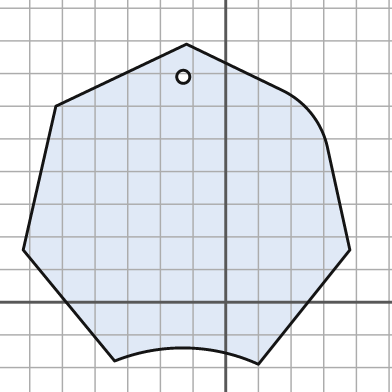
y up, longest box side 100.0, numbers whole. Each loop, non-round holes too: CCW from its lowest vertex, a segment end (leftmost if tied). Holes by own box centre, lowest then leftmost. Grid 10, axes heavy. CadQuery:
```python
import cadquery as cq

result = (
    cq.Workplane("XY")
    .moveTo(10.0, -19.0)
    .lineTo(38.0, 16.0)
    .lineTo(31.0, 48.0)
    .threePointArc((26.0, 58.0), (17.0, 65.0))
    .lineTo(-12.0, 79.0)
    .lineTo(-52.0, 60.0)
    .lineTo(-62.0, 16.0)
    .lineTo(-34.0, -18.0)
    .threePointArc((-12.0, -14.0), (10.0, -19.0))
    .close()
    .moveTo(-13.0, 69.0)
    .circle(2.0)
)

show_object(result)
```